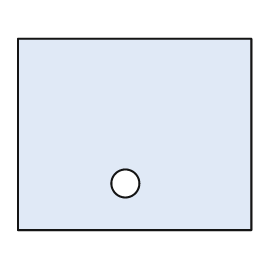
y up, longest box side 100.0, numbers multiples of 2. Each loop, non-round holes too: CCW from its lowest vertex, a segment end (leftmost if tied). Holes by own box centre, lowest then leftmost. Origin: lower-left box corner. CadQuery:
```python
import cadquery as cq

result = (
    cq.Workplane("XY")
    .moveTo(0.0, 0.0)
    .lineTo(100.0, 0.0)
    .lineTo(100.0, 82.0)
    .lineTo(0.0, 82.0)
    .close()
    .moveTo(46.0, 20.0)
    .circle(6.0)
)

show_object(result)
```